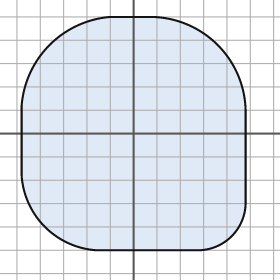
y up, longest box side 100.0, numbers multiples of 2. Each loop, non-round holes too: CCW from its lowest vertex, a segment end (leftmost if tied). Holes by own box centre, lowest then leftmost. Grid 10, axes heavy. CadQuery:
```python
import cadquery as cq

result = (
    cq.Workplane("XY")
    .moveTo(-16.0, -50.0)
    .lineTo(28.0, -50.0)
    .threePointArc((42.0, -44.0), (48.0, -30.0))
    .lineTo(48.0, 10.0)
    .threePointArc((36.0, 38.0), (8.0, 50.0))
    .lineTo(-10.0, 50.0)
    .threePointArc((-36.0, 38.0), (-48.0, 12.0))
    .lineTo(-48.0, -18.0)
    .threePointArc((-38.0, -40.0), (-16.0, -50.0))
    .close()
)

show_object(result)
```